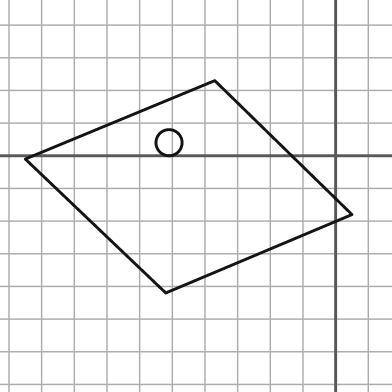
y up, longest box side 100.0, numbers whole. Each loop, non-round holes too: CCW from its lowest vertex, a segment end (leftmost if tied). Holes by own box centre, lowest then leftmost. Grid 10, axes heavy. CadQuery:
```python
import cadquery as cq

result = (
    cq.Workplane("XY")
    .moveTo(-52.0, -42.0)
    .lineTo(5.0, -18.0)
    .lineTo(-37.0, 23.0)
    .lineTo(-95.0, -1.0)
    .close()
    .moveTo(-51.0, 4.0)
    .circle(4.0)
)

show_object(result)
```